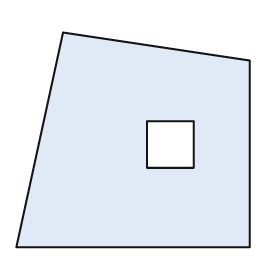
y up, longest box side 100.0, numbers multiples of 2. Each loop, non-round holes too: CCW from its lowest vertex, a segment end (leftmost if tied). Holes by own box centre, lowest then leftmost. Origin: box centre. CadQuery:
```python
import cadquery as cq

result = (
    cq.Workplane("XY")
    .moveTo(-50.0, -46.0)
    .lineTo(50.0, -46.0)
    .lineTo(50.0, 34.0)
    .lineTo(-30.0, 46.0)
    .close()
    .moveTo(6.0, -12.0)
    .lineTo(26.0, -12.0)
    .lineTo(26.0, 8.0)
    .lineTo(6.0, 8.0)
    .close()
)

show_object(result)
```